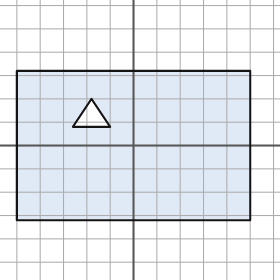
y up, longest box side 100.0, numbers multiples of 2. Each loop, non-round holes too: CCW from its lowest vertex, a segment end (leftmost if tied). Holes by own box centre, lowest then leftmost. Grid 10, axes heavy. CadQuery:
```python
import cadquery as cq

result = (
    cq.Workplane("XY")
    .moveTo(-50.0, -32.0)
    .lineTo(50.0, -32.0)
    .lineTo(50.0, 32.0)
    .lineTo(-50.0, 32.0)
    .close()
    .moveTo(-26.0, 8.0)
    .lineTo(-10.0, 8.0)
    .lineTo(-18.0, 20.0)
    .close()
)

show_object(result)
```